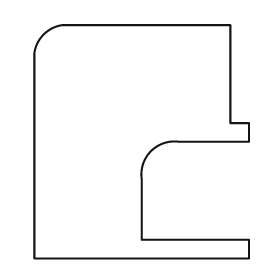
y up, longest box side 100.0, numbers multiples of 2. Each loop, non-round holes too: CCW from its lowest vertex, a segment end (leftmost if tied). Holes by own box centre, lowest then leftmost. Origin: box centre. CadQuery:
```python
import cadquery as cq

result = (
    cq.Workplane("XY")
    .moveTo(-46.0, -50.0)
    .lineTo(46.0, -50.0)
    .lineTo(46.0, -42.0)
    .lineTo(0.0, -42.0)
    .lineTo(0.0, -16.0)
    .threePointArc((4.0, -4.0), (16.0, 0.0))
    .lineTo(46.0, 0.0)
    .lineTo(46.0, 8.0)
    .lineTo(38.0, 8.0)
    .lineTo(38.0, 50.0)
    .lineTo(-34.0, 50.0)
    .threePointArc((-42.0, 46.0), (-46.0, 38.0))
    .close()
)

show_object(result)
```